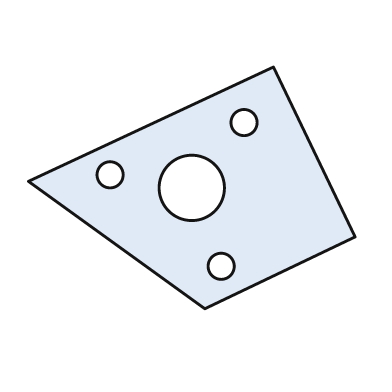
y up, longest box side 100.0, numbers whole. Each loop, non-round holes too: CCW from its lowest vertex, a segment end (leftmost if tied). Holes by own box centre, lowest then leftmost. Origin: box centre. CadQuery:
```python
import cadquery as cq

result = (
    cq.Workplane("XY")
    .moveTo(4.0, -37.0)
    .lineTo(50.0, -15.0)
    .lineTo(25.0, 37.0)
    .lineTo(-50.0, 2.0)
    .close()
    .moveTo(9.0, -24.0)
    .circle(4.0)
    .moveTo(0.0, 0.0)
    .circle(10.0)
    .moveTo(-25.0, 4.0)
    .circle(4.0)
    .moveTo(16.0, 20.0)
    .circle(4.0)
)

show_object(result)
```